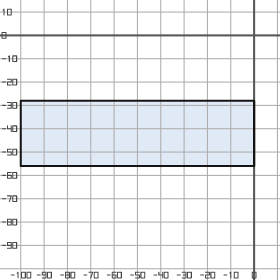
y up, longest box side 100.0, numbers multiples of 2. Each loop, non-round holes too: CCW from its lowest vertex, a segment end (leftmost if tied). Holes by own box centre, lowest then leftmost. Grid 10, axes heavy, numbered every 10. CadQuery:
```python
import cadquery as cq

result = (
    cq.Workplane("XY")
    .moveTo(-100.0, -56.0)
    .lineTo(0.0, -56.0)
    .lineTo(0.0, -28.0)
    .lineTo(-100.0, -28.0)
    .close()
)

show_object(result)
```